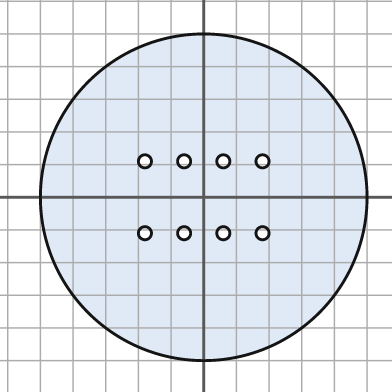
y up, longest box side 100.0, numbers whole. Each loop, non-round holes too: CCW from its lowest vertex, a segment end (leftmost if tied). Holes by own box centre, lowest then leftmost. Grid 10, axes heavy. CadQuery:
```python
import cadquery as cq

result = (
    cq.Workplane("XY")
    .moveTo(0.0, 0.0)
    .circle(50.0)
    .moveTo(-18.0, -11.0)
    .circle(2.0)
    .moveTo(-6.0, -11.0)
    .circle(2.0)
    .moveTo(6.0, -11.0)
    .circle(2.0)
    .moveTo(18.0, -11.0)
    .circle(2.0)
    .moveTo(-18.0, 11.0)
    .circle(2.0)
    .moveTo(-6.0, 11.0)
    .circle(2.0)
    .moveTo(6.0, 11.0)
    .circle(2.0)
    .moveTo(18.0, 11.0)
    .circle(2.0)
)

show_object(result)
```